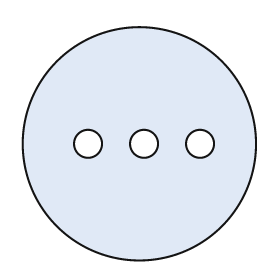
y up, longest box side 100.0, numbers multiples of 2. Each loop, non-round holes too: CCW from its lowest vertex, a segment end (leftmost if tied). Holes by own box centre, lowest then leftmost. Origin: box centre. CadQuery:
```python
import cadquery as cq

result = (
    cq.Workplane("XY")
    .moveTo(0.0, 0.0)
    .circle(50.0)
    .moveTo(-22.0, 0.0)
    .circle(6.0)
    .moveTo(2.0, 0.0)
    .circle(6.0)
    .moveTo(26.0, 0.0)
    .circle(6.0)
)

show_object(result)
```